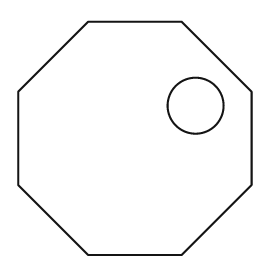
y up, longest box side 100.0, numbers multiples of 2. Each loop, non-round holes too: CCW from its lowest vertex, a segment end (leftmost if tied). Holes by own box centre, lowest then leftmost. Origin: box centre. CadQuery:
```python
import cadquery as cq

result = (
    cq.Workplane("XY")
    .moveTo(-20.0, -50.0)
    .lineTo(20.0, -50.0)
    .lineTo(50.0, -20.0)
    .lineTo(50.0, 20.0)
    .lineTo(20.0, 50.0)
    .lineTo(-20.0, 50.0)
    .lineTo(-50.0, 20.0)
    .lineTo(-50.0, -20.0)
    .close()
    .moveTo(26.0, 14.0)
    .circle(12.0)
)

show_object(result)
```